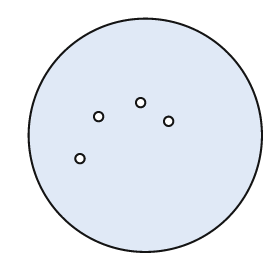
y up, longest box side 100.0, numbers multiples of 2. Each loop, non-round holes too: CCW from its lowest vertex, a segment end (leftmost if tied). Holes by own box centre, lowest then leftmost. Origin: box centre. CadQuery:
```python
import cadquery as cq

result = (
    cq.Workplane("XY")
    .moveTo(0.0, 0.0)
    .circle(50.0)
    .moveTo(-28.0, -10.0)
    .circle(2.0)
    .moveTo(10.0, 6.0)
    .circle(2.0)
    .moveTo(-20.0, 8.0)
    .circle(2.0)
    .moveTo(-2.0, 14.0)
    .circle(2.0)
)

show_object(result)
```